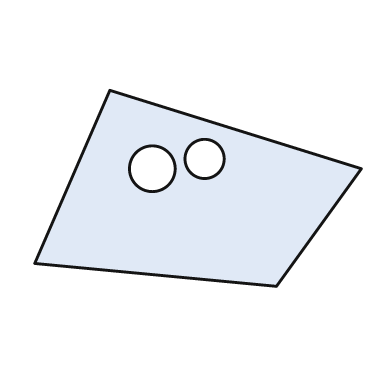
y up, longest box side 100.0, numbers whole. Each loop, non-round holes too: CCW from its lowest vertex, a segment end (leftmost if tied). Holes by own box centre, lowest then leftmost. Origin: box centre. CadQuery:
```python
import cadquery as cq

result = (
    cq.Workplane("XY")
    .moveTo(24.0, -30.0)
    .lineTo(50.0, 6.0)
    .lineTo(-27.0, 30.0)
    .lineTo(-50.0, -23.0)
    .close()
    .moveTo(-14.0, 6.0)
    .circle(7.0)
    .moveTo(2.0, 9.0)
    .circle(6.0)
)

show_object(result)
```